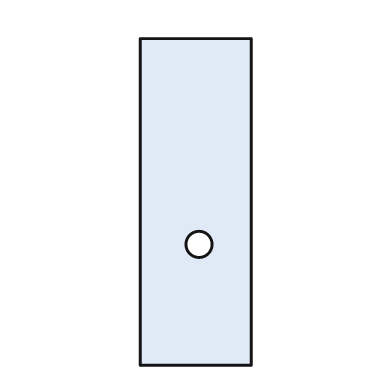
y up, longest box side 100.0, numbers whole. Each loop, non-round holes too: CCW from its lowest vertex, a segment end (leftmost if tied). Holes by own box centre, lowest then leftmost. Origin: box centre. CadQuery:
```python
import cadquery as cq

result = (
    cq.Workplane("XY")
    .moveTo(-17.0, -50.0)
    .lineTo(17.0, -50.0)
    .lineTo(17.0, 50.0)
    .lineTo(-17.0, 50.0)
    .close()
    .moveTo(1.0, -13.0)
    .circle(4.0)
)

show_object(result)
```